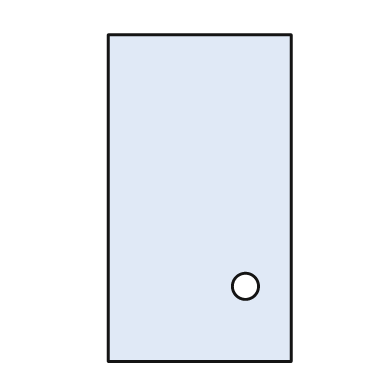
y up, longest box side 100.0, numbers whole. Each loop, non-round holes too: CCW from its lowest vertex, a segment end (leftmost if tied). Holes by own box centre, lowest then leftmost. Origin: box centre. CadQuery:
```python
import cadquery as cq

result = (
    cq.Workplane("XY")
    .moveTo(-28.0, -50.0)
    .lineTo(28.0, -50.0)
    .lineTo(28.0, 50.0)
    .lineTo(-28.0, 50.0)
    .close()
    .moveTo(14.0, -27.0)
    .circle(4.0)
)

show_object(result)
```